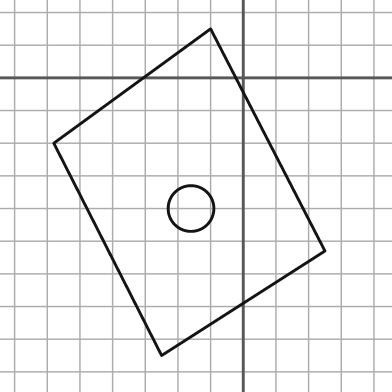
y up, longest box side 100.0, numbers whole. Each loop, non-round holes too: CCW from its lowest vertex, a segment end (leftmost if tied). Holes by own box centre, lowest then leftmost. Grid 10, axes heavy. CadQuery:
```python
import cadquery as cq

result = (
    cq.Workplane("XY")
    .moveTo(-25.0, -85.0)
    .lineTo(25.0, -53.0)
    .lineTo(-10.0, 15.0)
    .lineTo(-58.0, -20.0)
    .close()
    .moveTo(-16.0, -40.0)
    .circle(7.0)
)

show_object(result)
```